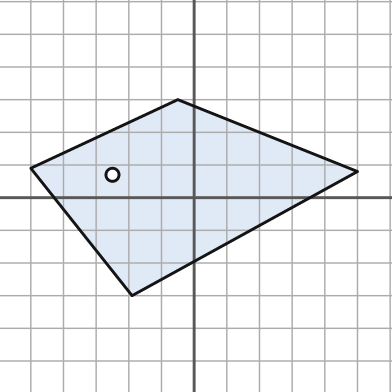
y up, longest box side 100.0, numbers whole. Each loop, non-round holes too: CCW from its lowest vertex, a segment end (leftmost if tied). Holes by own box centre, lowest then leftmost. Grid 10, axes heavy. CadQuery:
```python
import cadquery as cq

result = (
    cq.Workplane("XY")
    .moveTo(-19.0, -30.0)
    .lineTo(50.0, 8.0)
    .lineTo(-5.0, 30.0)
    .lineTo(-50.0, 9.0)
    .close()
    .moveTo(-25.0, 7.0)
    .circle(2.0)
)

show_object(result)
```